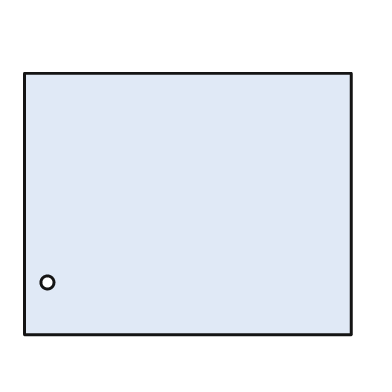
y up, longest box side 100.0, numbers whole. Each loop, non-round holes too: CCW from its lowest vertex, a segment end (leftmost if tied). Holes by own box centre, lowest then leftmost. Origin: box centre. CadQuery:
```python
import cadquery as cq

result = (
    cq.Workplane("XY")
    .moveTo(-50.0, -40.0)
    .lineTo(50.0, -40.0)
    .lineTo(50.0, 40.0)
    .lineTo(-50.0, 40.0)
    .close()
    .moveTo(-43.0, -24.0)
    .circle(2.0)
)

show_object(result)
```